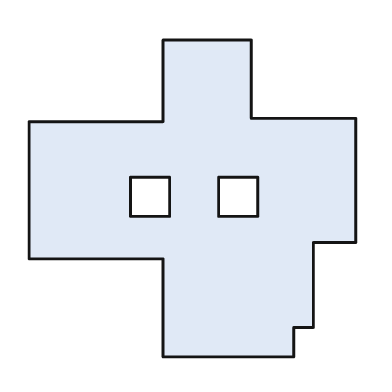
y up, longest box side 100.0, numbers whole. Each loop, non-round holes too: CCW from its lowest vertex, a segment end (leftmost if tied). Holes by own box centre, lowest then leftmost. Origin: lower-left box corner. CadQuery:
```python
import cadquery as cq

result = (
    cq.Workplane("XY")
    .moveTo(41.0, 0.0)
    .lineTo(81.0, 0.0)
    .lineTo(81.0, 9.0)
    .lineTo(87.0, 9.0)
    .lineTo(87.0, 35.0)
    .lineTo(100.0, 35.0)
    .lineTo(100.0, 73.0)
    .lineTo(68.0, 73.0)
    .lineTo(68.0, 97.0)
    .lineTo(41.0, 97.0)
    .lineTo(41.0, 72.0)
    .lineTo(0.0, 72.0)
    .lineTo(0.0, 30.0)
    .lineTo(41.0, 30.0)
    .close()
    .moveTo(31.0, 43.0)
    .lineTo(43.0, 43.0)
    .lineTo(43.0, 55.0)
    .lineTo(31.0, 55.0)
    .close()
    .moveTo(58.0, 43.0)
    .lineTo(70.0, 43.0)
    .lineTo(70.0, 55.0)
    .lineTo(58.0, 55.0)
    .close()
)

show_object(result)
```